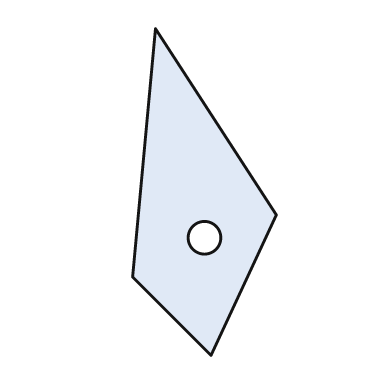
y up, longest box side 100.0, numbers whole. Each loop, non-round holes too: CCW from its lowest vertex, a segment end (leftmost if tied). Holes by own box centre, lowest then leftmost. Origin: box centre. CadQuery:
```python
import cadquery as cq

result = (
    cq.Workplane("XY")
    .moveTo(2.0, -50.0)
    .lineTo(22.0, -7.0)
    .lineTo(-15.0, 50.0)
    .lineTo(-22.0, -26.0)
    .close()
    .moveTo(0.0, -14.0)
    .circle(5.0)
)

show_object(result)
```